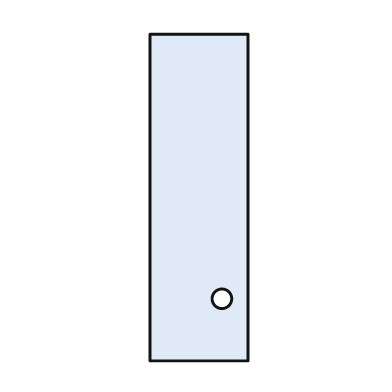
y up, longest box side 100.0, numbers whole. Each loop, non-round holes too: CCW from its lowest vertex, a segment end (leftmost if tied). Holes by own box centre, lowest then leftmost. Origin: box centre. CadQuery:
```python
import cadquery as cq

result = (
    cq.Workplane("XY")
    .moveTo(-15.0, -50.0)
    .lineTo(15.0, -50.0)
    .lineTo(15.0, 50.0)
    .lineTo(-15.0, 50.0)
    .close()
    .moveTo(7.0, -31.0)
    .circle(3.0)
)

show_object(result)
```